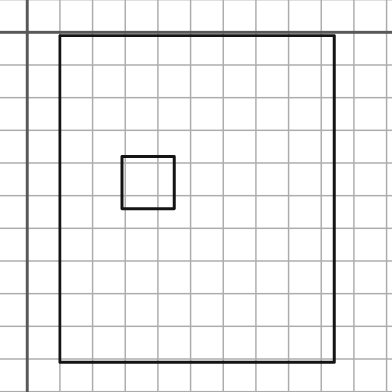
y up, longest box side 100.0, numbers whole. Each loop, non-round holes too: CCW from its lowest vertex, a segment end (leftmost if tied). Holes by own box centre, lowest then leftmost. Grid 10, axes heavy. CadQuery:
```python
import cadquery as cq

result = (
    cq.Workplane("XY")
    .moveTo(10.0, -101.0)
    .lineTo(94.0, -101.0)
    .lineTo(94.0, -1.0)
    .lineTo(10.0, -1.0)
    .close()
    .moveTo(29.0, -54.0)
    .lineTo(45.0, -54.0)
    .lineTo(45.0, -38.0)
    .lineTo(29.0, -38.0)
    .close()
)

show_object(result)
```